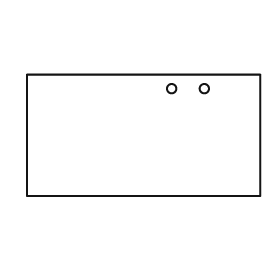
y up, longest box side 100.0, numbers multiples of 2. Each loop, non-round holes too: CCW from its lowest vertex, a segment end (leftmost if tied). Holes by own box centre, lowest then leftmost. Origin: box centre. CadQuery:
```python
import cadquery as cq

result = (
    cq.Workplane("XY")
    .moveTo(-50.0, -26.0)
    .lineTo(50.0, -26.0)
    .lineTo(50.0, 26.0)
    .lineTo(-50.0, 26.0)
    .close()
    .moveTo(12.0, 20.0)
    .circle(2.0)
    .moveTo(26.0, 20.0)
    .circle(2.0)
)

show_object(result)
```